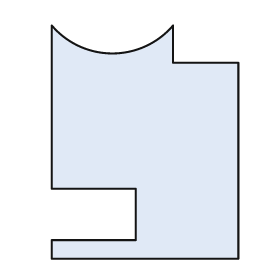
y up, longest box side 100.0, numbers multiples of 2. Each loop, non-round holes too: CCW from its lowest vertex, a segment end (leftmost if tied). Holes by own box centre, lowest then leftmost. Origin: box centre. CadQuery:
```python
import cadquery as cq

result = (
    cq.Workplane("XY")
    .moveTo(-40.0, -50.0)
    .lineTo(40.0, -50.0)
    .lineTo(40.0, 34.0)
    .lineTo(12.0, 34.0)
    .lineTo(12.0, 50.0)
    .threePointArc((-14.0, 38.0), (-40.0, 50.0))
    .lineTo(-40.0, -20.0)
    .lineTo(-4.0, -20.0)
    .lineTo(-4.0, -42.0)
    .lineTo(-40.0, -42.0)
    .close()
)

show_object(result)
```